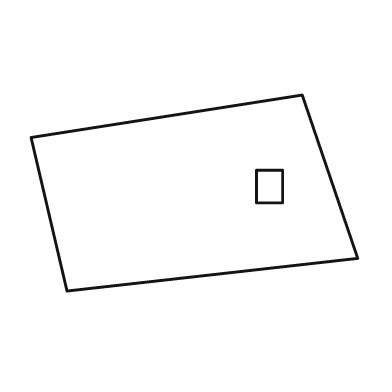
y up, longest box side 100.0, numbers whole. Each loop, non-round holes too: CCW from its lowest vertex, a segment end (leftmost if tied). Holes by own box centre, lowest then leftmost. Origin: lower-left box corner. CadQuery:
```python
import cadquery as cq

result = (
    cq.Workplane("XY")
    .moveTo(11.0, 0.0)
    .lineTo(100.0, 10.0)
    .lineTo(83.0, 60.0)
    .lineTo(0.0, 47.0)
    .close()
    .moveTo(69.0, 27.0)
    .lineTo(77.0, 27.0)
    .lineTo(77.0, 37.0)
    .lineTo(69.0, 37.0)
    .close()
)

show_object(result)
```